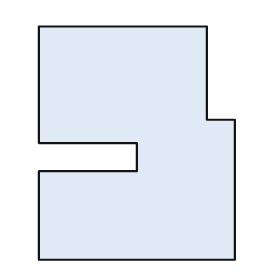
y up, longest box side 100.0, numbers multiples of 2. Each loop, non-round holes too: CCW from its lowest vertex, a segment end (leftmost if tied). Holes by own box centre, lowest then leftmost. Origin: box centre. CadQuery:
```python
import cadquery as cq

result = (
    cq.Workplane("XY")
    .moveTo(-42.0, -50.0)
    .lineTo(42.0, -50.0)
    .lineTo(42.0, 10.0)
    .lineTo(30.0, 10.0)
    .lineTo(30.0, 50.0)
    .lineTo(-42.0, 50.0)
    .lineTo(-42.0, 0.0)
    .lineTo(0.0, 0.0)
    .lineTo(0.0, -12.0)
    .lineTo(-42.0, -12.0)
    .close()
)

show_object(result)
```